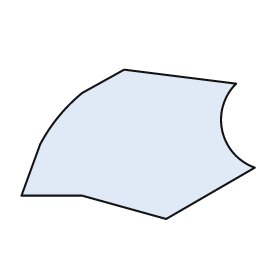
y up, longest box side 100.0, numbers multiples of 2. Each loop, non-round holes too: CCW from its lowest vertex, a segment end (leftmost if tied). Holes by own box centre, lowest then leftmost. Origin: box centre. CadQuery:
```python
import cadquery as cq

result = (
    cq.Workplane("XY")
    .moveTo(12.0, -32.0)
    .lineTo(50.0, -10.0)
    .threePointArc((36.0, 6.0), (42.0, 26.0))
    .lineTo(-6.0, 32.0)
    .lineTo(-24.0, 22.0)
    .threePointArc((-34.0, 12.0), (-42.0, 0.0))
    .lineTo(-50.0, -22.0)
    .lineTo(-24.0, -22.0)
    .close()
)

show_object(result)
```